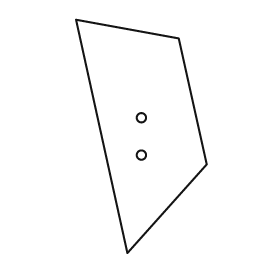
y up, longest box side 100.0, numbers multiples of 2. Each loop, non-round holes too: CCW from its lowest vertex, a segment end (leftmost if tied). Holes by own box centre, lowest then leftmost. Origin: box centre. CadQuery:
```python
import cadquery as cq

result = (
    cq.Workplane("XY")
    .moveTo(-6.0, -50.0)
    .lineTo(28.0, -12.0)
    .lineTo(16.0, 42.0)
    .lineTo(-28.0, 50.0)
    .close()
    .moveTo(0.0, -8.0)
    .circle(2.0)
    .moveTo(0.0, 8.0)
    .circle(2.0)
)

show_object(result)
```